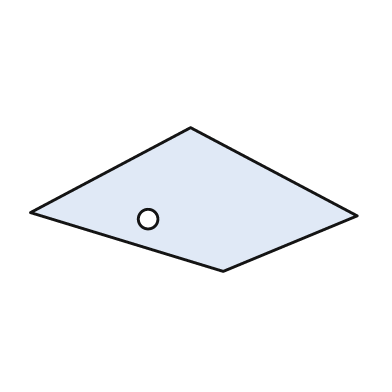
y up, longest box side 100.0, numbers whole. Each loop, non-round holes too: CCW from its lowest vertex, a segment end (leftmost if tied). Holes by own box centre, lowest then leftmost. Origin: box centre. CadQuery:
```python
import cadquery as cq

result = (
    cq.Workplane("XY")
    .moveTo(9.0, -22.0)
    .lineTo(50.0, -5.0)
    .lineTo(-1.0, 22.0)
    .lineTo(-50.0, -4.0)
    .close()
    .moveTo(-14.0, -6.0)
    .circle(3.0)
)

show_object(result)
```